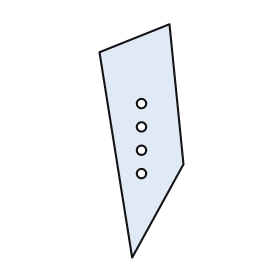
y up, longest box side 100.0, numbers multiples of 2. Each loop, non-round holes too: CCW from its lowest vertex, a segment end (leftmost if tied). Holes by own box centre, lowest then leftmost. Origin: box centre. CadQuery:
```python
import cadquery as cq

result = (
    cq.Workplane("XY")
    .moveTo(-4.0, -50.0)
    .lineTo(18.0, -10.0)
    .lineTo(12.0, 50.0)
    .lineTo(-18.0, 38.0)
    .close()
    .moveTo(0.0, -14.0)
    .circle(2.0)
    .moveTo(0.0, -4.0)
    .circle(2.0)
    .moveTo(0.0, 6.0)
    .circle(2.0)
    .moveTo(0.0, 16.0)
    .circle(2.0)
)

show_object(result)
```